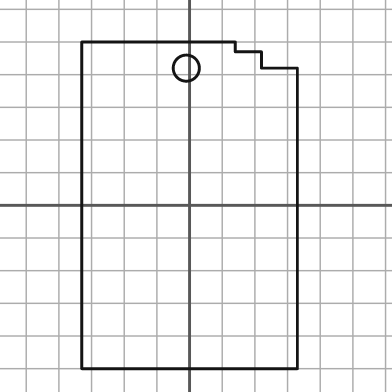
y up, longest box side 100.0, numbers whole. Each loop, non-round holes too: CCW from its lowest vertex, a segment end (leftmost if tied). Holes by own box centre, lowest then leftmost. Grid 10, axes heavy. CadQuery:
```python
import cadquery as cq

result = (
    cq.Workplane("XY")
    .moveTo(-33.0, -50.0)
    .lineTo(33.0, -50.0)
    .lineTo(33.0, 42.0)
    .lineTo(22.0, 42.0)
    .lineTo(22.0, 47.0)
    .lineTo(14.0, 47.0)
    .lineTo(14.0, 50.0)
    .lineTo(-33.0, 50.0)
    .close()
    .moveTo(-1.0, 42.0)
    .circle(4.0)
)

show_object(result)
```